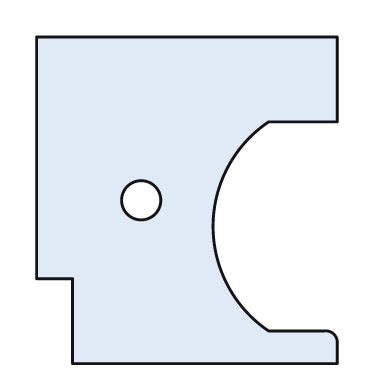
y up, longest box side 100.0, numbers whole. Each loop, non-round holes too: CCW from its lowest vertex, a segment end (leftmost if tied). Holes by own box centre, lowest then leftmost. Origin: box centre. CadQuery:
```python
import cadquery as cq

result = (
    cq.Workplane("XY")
    .moveTo(-35.0, -50.0)
    .lineTo(46.0, -50.0)
    .lineTo(46.0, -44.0)
    .threePointArc((45.0, -41.0), (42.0, -40.0))
    .lineTo(25.0, -40.0)
    .threePointArc((8.0, -8.0), (25.0, 24.0))
    .lineTo(46.0, 24.0)
    .lineTo(46.0, 50.0)
    .lineTo(-46.0, 50.0)
    .lineTo(-46.0, -24.0)
    .lineTo(-35.0, -24.0)
    .close()
    .moveTo(-14.0, 0.0)
    .circle(6.0)
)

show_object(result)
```